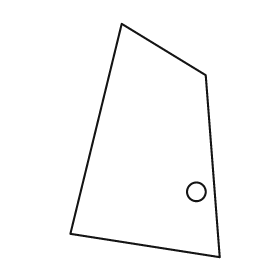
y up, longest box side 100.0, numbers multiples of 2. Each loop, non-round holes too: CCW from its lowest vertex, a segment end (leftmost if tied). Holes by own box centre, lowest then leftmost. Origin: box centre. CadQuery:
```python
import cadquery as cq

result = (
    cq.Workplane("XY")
    .moveTo(32.0, -50.0)
    .lineTo(26.0, 28.0)
    .lineTo(-10.0, 50.0)
    .lineTo(-32.0, -40.0)
    .close()
    .moveTo(22.0, -22.0)
    .circle(4.0)
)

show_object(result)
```